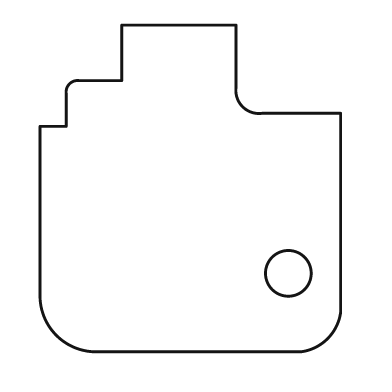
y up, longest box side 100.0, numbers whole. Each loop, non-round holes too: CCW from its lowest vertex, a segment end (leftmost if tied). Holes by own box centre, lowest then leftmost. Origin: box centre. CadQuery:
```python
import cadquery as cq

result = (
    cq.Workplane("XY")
    .moveTo(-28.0, -50.0)
    .lineTo(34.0, -50.0)
    .threePointArc((42.0, -46.0), (46.0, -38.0))
    .lineTo(46.0, 23.0)
    .lineTo(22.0, 23.0)
    .threePointArc((16.0, 25.0), (14.0, 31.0))
    .lineTo(14.0, 50.0)
    .lineTo(-21.0, 50.0)
    .lineTo(-21.0, 33.0)
    .lineTo(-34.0, 33.0)
    .threePointArc((-37.0, 32.0), (-38.0, 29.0))
    .lineTo(-38.0, 19.0)
    .lineTo(-46.0, 19.0)
    .lineTo(-46.0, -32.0)
    .threePointArc((-41.0, -45.0), (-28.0, -50.0))
    .close()
    .moveTo(30.0, -26.0)
    .circle(7.0)
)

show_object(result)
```